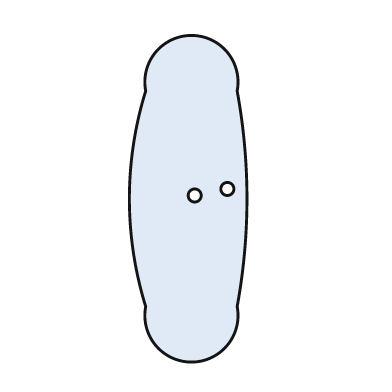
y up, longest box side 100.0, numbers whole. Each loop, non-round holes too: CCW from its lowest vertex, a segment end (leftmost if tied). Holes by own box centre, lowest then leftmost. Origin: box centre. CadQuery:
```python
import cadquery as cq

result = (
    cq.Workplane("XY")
    .moveTo(-13.0, -33.0)
    .threePointArc((1.0, -50.0), (15.0, -33.0))
    .threePointArc((18.0, 0.0), (15.0, 33.0))
    .threePointArc((1.0, 50.0), (-13.0, 33.0))
    .threePointArc((-18.0, 0.0), (-13.0, -33.0))
    .close()
    .moveTo(2.0, 1.0)
    .circle(2.0)
    .moveTo(12.0, 3.0)
    .circle(2.0)
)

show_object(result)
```